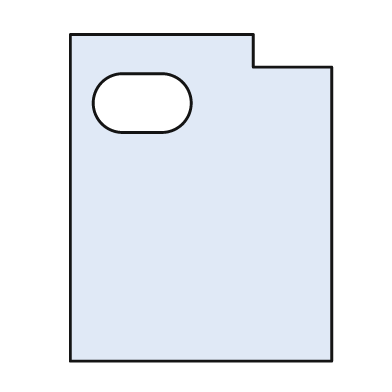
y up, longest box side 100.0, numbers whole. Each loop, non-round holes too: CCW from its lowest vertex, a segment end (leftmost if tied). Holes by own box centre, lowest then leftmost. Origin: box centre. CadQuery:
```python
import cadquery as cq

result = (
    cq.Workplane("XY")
    .moveTo(-40.0, -50.0)
    .lineTo(40.0, -50.0)
    .lineTo(40.0, 40.0)
    .lineTo(16.0, 40.0)
    .lineTo(16.0, 50.0)
    .lineTo(-40.0, 50.0)
    .close()
    .moveTo(-24.0, 20.0)
    .lineTo(-12.0, 20.0)
    .threePointArc((-3.0, 29.0), (-12.0, 38.0))
    .lineTo(-24.0, 38.0)
    .threePointArc((-33.0, 29.0), (-24.0, 20.0))
    .close()
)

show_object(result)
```